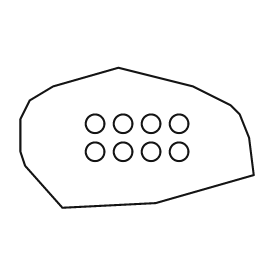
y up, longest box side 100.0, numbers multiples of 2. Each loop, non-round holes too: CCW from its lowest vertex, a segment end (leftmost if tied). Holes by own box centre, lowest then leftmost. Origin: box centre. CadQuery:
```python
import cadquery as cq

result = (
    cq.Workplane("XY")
    .moveTo(-32.0, -30.0)
    .lineTo(8.0, -28.0)
    .lineTo(50.0, -16.0)
    .lineTo(48.0, 0.0)
    .lineTo(44.0, 10.0)
    .lineTo(40.0, 14.0)
    .lineTo(24.0, 22.0)
    .lineTo(-8.0, 30.0)
    .lineTo(-36.0, 22.0)
    .lineTo(-46.0, 16.0)
    .lineTo(-50.0, 8.0)
    .lineTo(-50.0, -6.0)
    .lineTo(-48.0, -12.0)
    .close()
    .moveTo(-18.0, -6.0)
    .circle(4.0)
    .moveTo(-6.0, -6.0)
    .circle(4.0)
    .moveTo(6.0, -6.0)
    .circle(4.0)
    .moveTo(18.0, -6.0)
    .circle(4.0)
    .moveTo(-18.0, 6.0)
    .circle(4.0)
    .moveTo(-6.0, 6.0)
    .circle(4.0)
    .moveTo(6.0, 6.0)
    .circle(4.0)
    .moveTo(18.0, 6.0)
    .circle(4.0)
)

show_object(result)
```